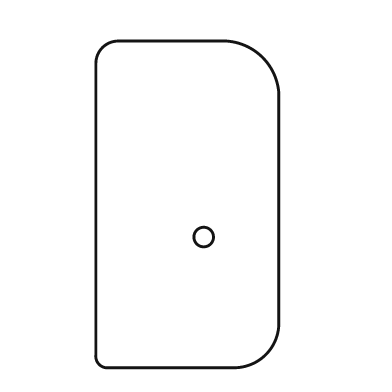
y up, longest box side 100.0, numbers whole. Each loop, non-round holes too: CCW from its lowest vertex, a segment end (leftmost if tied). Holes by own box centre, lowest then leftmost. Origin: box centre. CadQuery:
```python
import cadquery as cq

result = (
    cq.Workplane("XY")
    .moveTo(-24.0, -50.0)
    .lineTo(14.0, -50.0)
    .threePointArc((24.0, -46.0), (28.0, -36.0))
    .lineTo(28.0, 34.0)
    .threePointArc((23.0, 45.0), (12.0, 50.0))
    .lineTo(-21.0, 50.0)
    .threePointArc((-26.0, 48.0), (-28.0, 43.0))
    .lineTo(-28.0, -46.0)
    .threePointArc((-27.0, -49.0), (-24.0, -50.0))
    .close()
    .moveTo(5.0, -10.0)
    .circle(3.0)
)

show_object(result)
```